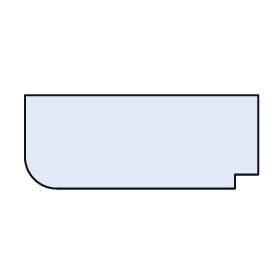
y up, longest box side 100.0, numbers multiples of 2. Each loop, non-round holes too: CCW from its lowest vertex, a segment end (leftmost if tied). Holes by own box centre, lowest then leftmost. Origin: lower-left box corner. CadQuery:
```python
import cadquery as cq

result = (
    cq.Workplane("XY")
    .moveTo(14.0, 0.0)
    .lineTo(90.0, 0.0)
    .lineTo(90.0, 6.0)
    .lineTo(100.0, 6.0)
    .lineTo(100.0, 40.0)
    .lineTo(0.0, 40.0)
    .lineTo(0.0, 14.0)
    .threePointArc((4.0, 4.0), (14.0, 0.0))
    .close()
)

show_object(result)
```